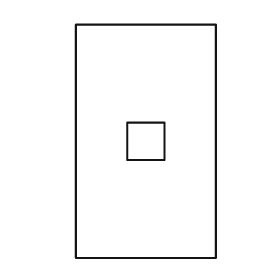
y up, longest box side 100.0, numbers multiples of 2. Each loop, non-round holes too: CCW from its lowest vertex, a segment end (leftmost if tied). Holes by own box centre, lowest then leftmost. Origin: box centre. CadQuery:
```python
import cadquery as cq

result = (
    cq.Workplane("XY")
    .moveTo(-30.0, -50.0)
    .lineTo(30.0, -50.0)
    .lineTo(30.0, 50.0)
    .lineTo(-30.0, 50.0)
    .close()
    .moveTo(-8.0, -8.0)
    .lineTo(8.0, -8.0)
    .lineTo(8.0, 8.0)
    .lineTo(-8.0, 8.0)
    .close()
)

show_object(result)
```